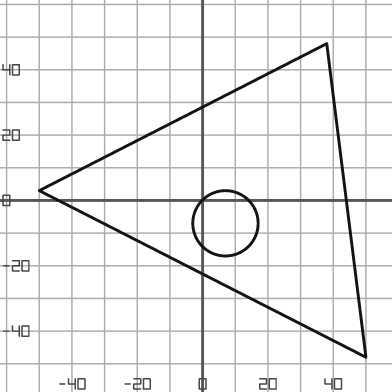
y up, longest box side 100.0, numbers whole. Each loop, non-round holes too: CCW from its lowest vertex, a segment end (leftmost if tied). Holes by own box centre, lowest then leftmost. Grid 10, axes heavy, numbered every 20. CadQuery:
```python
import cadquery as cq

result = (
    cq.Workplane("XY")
    .moveTo(50.0, -48.0)
    .lineTo(38.0, 48.0)
    .lineTo(-50.0, 3.0)
    .close()
    .moveTo(7.0, -7.0)
    .circle(10.0)
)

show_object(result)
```